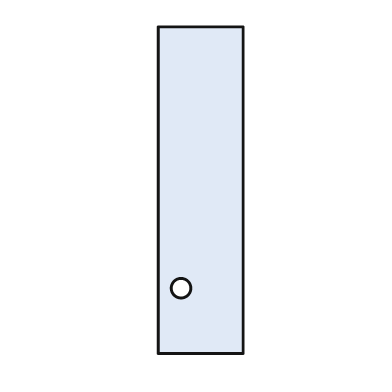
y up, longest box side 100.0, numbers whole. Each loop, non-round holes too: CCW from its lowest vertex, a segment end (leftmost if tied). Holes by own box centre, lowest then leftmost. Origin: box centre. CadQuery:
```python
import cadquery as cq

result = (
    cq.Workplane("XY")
    .moveTo(-13.0, -50.0)
    .lineTo(13.0, -50.0)
    .lineTo(13.0, 50.0)
    .lineTo(-13.0, 50.0)
    .close()
    .moveTo(-6.0, -30.0)
    .circle(3.0)
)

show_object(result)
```